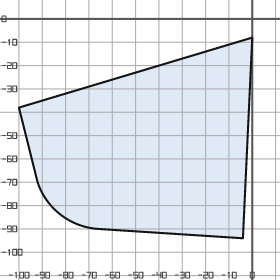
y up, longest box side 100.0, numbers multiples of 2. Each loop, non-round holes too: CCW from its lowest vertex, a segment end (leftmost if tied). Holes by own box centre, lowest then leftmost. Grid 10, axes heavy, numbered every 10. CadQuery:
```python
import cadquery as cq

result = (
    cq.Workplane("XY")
    .moveTo(-4.0, -94.0)
    .lineTo(0.0, -8.0)
    .lineTo(-100.0, -38.0)
    .lineTo(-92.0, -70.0)
    .threePointArc((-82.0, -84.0), (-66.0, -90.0))
    .close()
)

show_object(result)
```